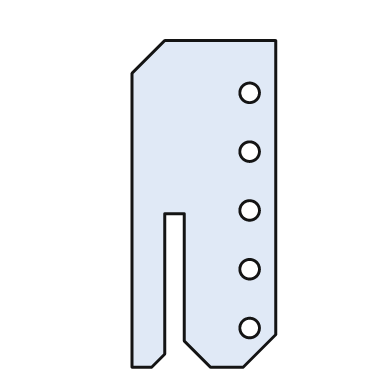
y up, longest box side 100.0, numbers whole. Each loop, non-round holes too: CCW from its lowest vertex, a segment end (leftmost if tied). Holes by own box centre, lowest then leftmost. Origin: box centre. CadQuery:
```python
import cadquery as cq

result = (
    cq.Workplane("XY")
    .moveTo(-22.0, -50.0)
    .lineTo(-16.0, -50.0)
    .lineTo(-12.0, -46.0)
    .lineTo(-12.0, -3.0)
    .lineTo(-6.0, -3.0)
    .lineTo(-6.0, -42.0)
    .lineTo(2.0, -50.0)
    .lineTo(12.0, -50.0)
    .lineTo(22.0, -40.0)
    .lineTo(22.0, 50.0)
    .lineTo(-12.0, 50.0)
    .lineTo(-22.0, 40.0)
    .close()
    .moveTo(14.0, -38.0)
    .circle(3.0)
    .moveTo(14.0, -20.0)
    .circle(3.0)
    .moveTo(14.0, -2.0)
    .circle(3.0)
    .moveTo(14.0, 16.0)
    .circle(3.0)
    .moveTo(14.0, 34.0)
    .circle(3.0)
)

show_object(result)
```